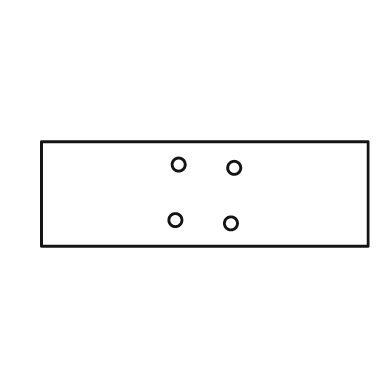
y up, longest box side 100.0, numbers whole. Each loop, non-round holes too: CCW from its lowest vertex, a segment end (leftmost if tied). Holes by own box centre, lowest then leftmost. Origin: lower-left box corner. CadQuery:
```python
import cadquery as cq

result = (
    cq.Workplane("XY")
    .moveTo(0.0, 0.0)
    .lineTo(100.0, 0.0)
    .lineTo(100.0, 32.0)
    .lineTo(0.0, 32.0)
    .close()
    .moveTo(58.0, 7.0)
    .circle(2.0)
    .moveTo(41.0, 8.0)
    .circle(2.0)
    .moveTo(59.0, 24.0)
    .circle(2.0)
    .moveTo(42.0, 25.0)
    .circle(2.0)
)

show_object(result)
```